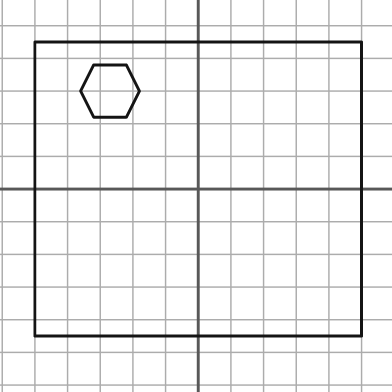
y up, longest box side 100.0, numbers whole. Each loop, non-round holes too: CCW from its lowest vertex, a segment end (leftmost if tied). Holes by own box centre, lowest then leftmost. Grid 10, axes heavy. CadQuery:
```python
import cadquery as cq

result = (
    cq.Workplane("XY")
    .moveTo(-50.0, -45.0)
    .lineTo(50.0, -45.0)
    .lineTo(50.0, 45.0)
    .lineTo(-50.0, 45.0)
    .close()
    .moveTo(-32.0, 22.0)
    .lineTo(-22.0, 22.0)
    .lineTo(-18.0, 30.0)
    .lineTo(-22.0, 38.0)
    .lineTo(-32.0, 38.0)
    .lineTo(-36.0, 30.0)
    .close()
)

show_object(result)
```